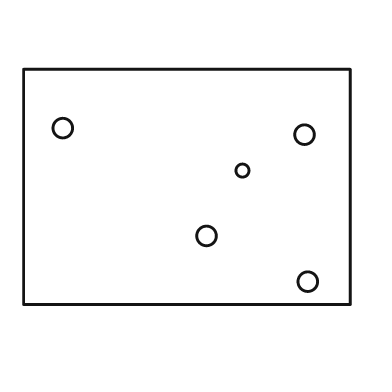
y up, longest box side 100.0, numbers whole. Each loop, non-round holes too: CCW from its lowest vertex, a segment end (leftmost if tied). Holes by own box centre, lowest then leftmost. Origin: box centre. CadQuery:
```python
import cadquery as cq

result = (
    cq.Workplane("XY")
    .moveTo(-50.0, -36.0)
    .lineTo(50.0, -36.0)
    .lineTo(50.0, 36.0)
    .lineTo(-50.0, 36.0)
    .close()
    .moveTo(37.0, -29.0)
    .circle(3.0)
    .moveTo(6.0, -15.0)
    .circle(3.0)
    .moveTo(17.0, 5.0)
    .circle(2.0)
    .moveTo(36.0, 16.0)
    .circle(3.0)
    .moveTo(-38.0, 18.0)
    .circle(3.0)
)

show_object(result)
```